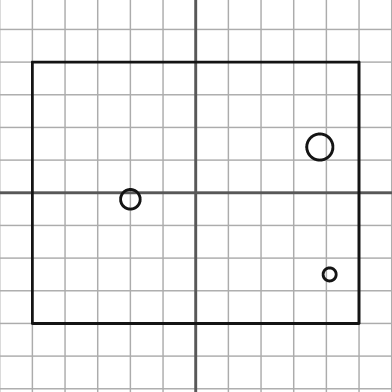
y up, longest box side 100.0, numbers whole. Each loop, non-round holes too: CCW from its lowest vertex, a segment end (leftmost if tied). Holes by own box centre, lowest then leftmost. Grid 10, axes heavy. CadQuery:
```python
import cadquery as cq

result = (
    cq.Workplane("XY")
    .moveTo(-50.0, -40.0)
    .lineTo(50.0, -40.0)
    .lineTo(50.0, 40.0)
    .lineTo(-50.0, 40.0)
    .close()
    .moveTo(41.0, -25.0)
    .circle(2.0)
    .moveTo(-20.0, -2.0)
    .circle(3.0)
    .moveTo(38.0, 14.0)
    .circle(4.0)
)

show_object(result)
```